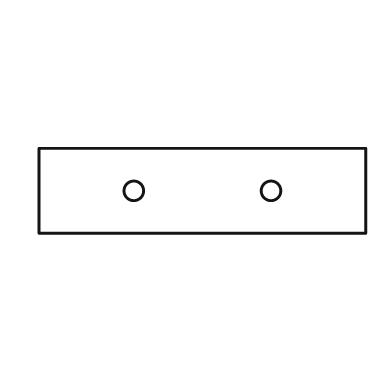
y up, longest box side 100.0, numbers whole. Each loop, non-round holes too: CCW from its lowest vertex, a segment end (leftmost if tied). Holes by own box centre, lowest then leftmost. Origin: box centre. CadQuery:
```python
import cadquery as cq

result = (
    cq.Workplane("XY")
    .moveTo(-50.0, -13.0)
    .lineTo(50.0, -13.0)
    .lineTo(50.0, 13.0)
    .lineTo(-50.0, 13.0)
    .close()
    .moveTo(-21.0, 0.0)
    .circle(3.0)
    .moveTo(21.0, 0.0)
    .circle(3.0)
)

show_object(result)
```